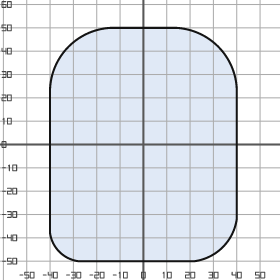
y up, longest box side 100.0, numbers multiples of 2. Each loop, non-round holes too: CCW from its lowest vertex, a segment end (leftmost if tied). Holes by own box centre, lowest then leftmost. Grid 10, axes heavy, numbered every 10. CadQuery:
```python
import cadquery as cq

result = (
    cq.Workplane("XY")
    .moveTo(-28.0, -50.0)
    .lineTo(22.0, -50.0)
    .threePointArc((34.0, -44.0), (40.0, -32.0))
    .lineTo(40.0, 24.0)
    .threePointArc((32.0, 42.0), (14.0, 50.0))
    .lineTo(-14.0, 50.0)
    .threePointArc((-32.0, 42.0), (-40.0, 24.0))
    .lineTo(-40.0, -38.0)
    .threePointArc((-36.0, -46.0), (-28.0, -50.0))
    .close()
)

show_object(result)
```